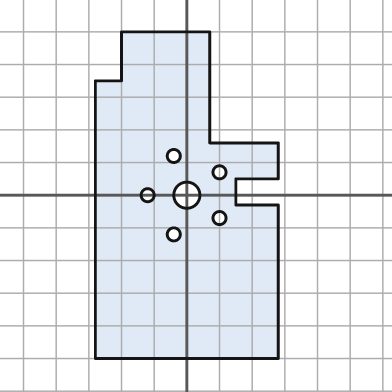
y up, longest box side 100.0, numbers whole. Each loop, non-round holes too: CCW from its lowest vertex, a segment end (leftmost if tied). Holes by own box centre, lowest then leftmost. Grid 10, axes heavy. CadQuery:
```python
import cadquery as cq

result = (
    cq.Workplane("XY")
    .moveTo(-28.0, -50.0)
    .lineTo(28.0, -50.0)
    .lineTo(28.0, -3.0)
    .lineTo(15.0, -3.0)
    .lineTo(15.0, 5.0)
    .lineTo(28.0, 5.0)
    .lineTo(28.0, 16.0)
    .lineTo(7.0, 16.0)
    .lineTo(7.0, 50.0)
    .lineTo(-20.0, 50.0)
    .lineTo(-20.0, 35.0)
    .lineTo(-28.0, 35.0)
    .close()
    .moveTo(-4.0, -12.0)
    .circle(2.0)
    .moveTo(10.0, -7.0)
    .circle(2.0)
    .moveTo(-12.0, 0.0)
    .circle(2.0)
    .moveTo(0.0, 0.0)
    .circle(4.0)
    .moveTo(10.0, 7.0)
    .circle(2.0)
    .moveTo(-4.0, 12.0)
    .circle(2.0)
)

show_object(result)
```